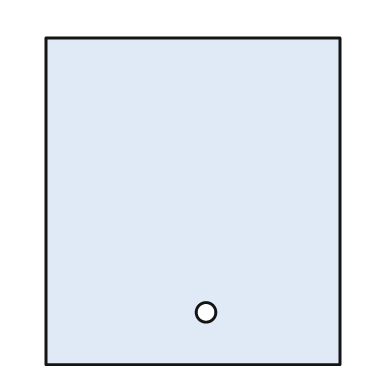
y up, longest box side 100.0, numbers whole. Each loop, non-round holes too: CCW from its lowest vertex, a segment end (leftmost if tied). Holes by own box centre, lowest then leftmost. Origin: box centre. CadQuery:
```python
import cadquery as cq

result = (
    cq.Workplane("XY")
    .moveTo(-45.0, -50.0)
    .lineTo(45.0, -50.0)
    .lineTo(45.0, 50.0)
    .lineTo(-45.0, 50.0)
    .close()
    .moveTo(4.0, -34.0)
    .circle(3.0)
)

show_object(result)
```